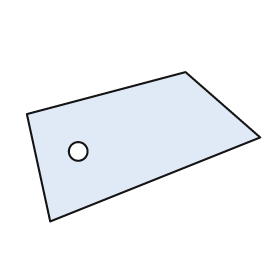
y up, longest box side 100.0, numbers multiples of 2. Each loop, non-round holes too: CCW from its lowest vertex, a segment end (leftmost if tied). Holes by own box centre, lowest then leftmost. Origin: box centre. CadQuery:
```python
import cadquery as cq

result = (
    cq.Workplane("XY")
    .moveTo(-40.0, -32.0)
    .lineTo(50.0, 4.0)
    .lineTo(18.0, 32.0)
    .lineTo(-50.0, 14.0)
    .close()
    .moveTo(-28.0, -2.0)
    .circle(4.0)
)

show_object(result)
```